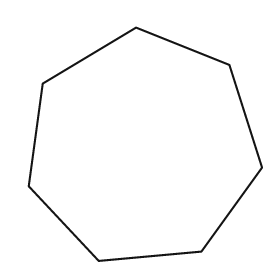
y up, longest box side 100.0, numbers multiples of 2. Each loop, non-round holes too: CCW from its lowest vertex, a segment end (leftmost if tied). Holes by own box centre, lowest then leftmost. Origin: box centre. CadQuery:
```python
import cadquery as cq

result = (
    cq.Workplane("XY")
    .moveTo(-20.0, -50.0)
    .lineTo(24.0, -46.0)
    .lineTo(50.0, -10.0)
    .lineTo(36.0, 34.0)
    .lineTo(-4.0, 50.0)
    .lineTo(-44.0, 26.0)
    .lineTo(-50.0, -18.0)
    .close()
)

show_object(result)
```